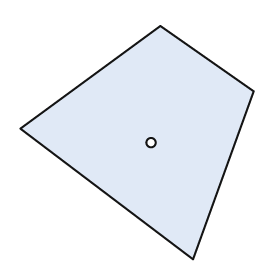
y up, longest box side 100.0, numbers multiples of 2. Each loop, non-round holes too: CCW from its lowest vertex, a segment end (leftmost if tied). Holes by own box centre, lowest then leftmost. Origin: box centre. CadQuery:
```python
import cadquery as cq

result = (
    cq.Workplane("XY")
    .moveTo(24.0, -50.0)
    .lineTo(50.0, 22.0)
    .lineTo(10.0, 50.0)
    .lineTo(-50.0, 6.0)
    .close()
    .moveTo(6.0, 0.0)
    .circle(2.0)
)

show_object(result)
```